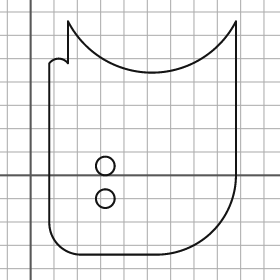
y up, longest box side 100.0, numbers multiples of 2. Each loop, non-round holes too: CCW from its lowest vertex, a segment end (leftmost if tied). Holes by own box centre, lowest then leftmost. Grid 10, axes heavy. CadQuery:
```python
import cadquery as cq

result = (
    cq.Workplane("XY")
    .moveTo(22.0, -34.0)
    .lineTo(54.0, -34.0)
    .threePointArc((78.0, -24.0), (88.0, 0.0))
    .lineTo(88.0, 66.0)
    .threePointArc((52.0, 44.0), (16.0, 66.0))
    .lineTo(16.0, 48.0)
    .threePointArc((12.0, 50.0), (8.0, 48.0))
    .lineTo(8.0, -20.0)
    .threePointArc((12.0, -30.0), (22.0, -34.0))
    .close()
    .moveTo(32.0, -10.0)
    .circle(4.0)
    .moveTo(32.0, 4.0)
    .circle(4.0)
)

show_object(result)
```